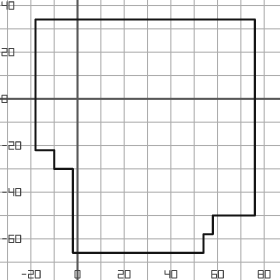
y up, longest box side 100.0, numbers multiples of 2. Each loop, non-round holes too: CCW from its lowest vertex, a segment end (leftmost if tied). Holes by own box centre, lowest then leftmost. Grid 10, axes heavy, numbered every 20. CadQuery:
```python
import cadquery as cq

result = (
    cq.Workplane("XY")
    .moveTo(-2.0, -66.0)
    .lineTo(54.0, -66.0)
    .lineTo(54.0, -58.0)
    .lineTo(58.0, -58.0)
    .lineTo(58.0, -50.0)
    .lineTo(76.0, -50.0)
    .lineTo(76.0, 34.0)
    .lineTo(-18.0, 34.0)
    .lineTo(-18.0, -22.0)
    .lineTo(-10.0, -22.0)
    .lineTo(-10.0, -30.0)
    .lineTo(-2.0, -30.0)
    .close()
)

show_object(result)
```